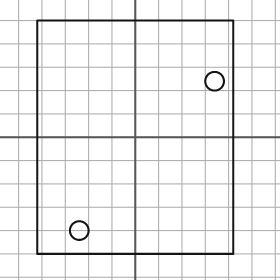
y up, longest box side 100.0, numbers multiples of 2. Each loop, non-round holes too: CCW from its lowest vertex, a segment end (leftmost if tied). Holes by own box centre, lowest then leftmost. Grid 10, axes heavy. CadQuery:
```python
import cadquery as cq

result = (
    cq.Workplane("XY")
    .moveTo(-42.0, -50.0)
    .lineTo(42.0, -50.0)
    .lineTo(42.0, 50.0)
    .lineTo(-42.0, 50.0)
    .close()
    .moveTo(-24.0, -40.0)
    .circle(4.0)
    .moveTo(34.0, 24.0)
    .circle(4.0)
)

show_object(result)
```